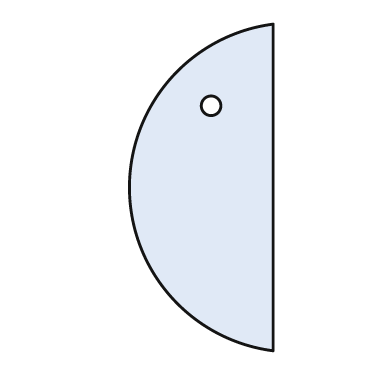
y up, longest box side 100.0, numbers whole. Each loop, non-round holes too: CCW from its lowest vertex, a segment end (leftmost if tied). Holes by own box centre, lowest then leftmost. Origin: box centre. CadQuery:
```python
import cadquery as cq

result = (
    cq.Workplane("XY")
    .moveTo(22.0, -50.0)
    .lineTo(22.0, 50.0)
    .threePointArc((-22.0, 0.0), (22.0, -50.0))
    .close()
    .moveTo(3.0, 25.0)
    .circle(3.0)
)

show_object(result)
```